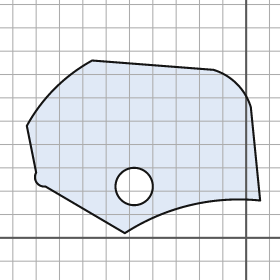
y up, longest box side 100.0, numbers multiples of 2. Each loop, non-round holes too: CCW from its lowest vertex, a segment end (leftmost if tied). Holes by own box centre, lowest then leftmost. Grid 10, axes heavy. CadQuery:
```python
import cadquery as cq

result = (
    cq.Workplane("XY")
    .moveTo(-52.0, 2.0)
    .threePointArc((-24.0, 14.0), (6.0, 16.0))
    .lineTo(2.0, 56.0)
    .threePointArc((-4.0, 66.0), (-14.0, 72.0))
    .lineTo(-66.0, 76.0)
    .threePointArc((-82.0, 64.0), (-94.0, 48.0))
    .lineTo(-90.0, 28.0)
    .threePointArc((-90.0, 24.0), (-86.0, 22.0))
    .close()
    .moveTo(-48.0, 22.0)
    .circle(8.0)
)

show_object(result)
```